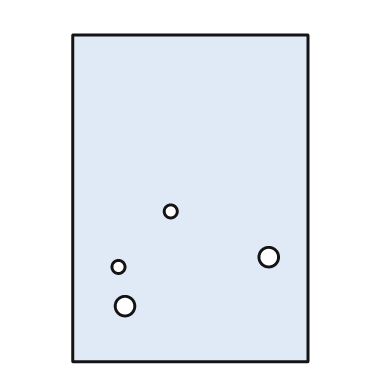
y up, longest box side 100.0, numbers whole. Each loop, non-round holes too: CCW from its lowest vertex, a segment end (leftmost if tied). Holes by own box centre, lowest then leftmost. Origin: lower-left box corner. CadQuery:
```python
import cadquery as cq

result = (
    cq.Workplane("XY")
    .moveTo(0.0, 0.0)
    .lineTo(72.0, 0.0)
    .lineTo(72.0, 100.0)
    .lineTo(0.0, 100.0)
    .close()
    .moveTo(16.0, 17.0)
    .circle(3.0)
    .moveTo(14.0, 29.0)
    .circle(2.0)
    .moveTo(60.0, 32.0)
    .circle(3.0)
    .moveTo(30.0, 46.0)
    .circle(2.0)
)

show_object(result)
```